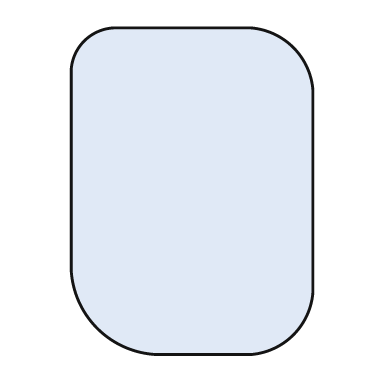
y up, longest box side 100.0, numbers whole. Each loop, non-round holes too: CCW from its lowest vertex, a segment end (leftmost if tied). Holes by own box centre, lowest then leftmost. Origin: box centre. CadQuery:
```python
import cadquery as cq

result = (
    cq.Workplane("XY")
    .moveTo(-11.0, -50.0)
    .lineTo(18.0, -50.0)
    .threePointArc((31.0, -44.0), (37.0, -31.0))
    .lineTo(37.0, 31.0)
    .threePointArc((31.0, 44.0), (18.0, 50.0))
    .lineTo(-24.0, 50.0)
    .threePointArc((-33.0, 46.0), (-37.0, 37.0))
    .lineTo(-37.0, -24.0)
    .threePointArc((-29.0, -42.0), (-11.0, -50.0))
    .close()
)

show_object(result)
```